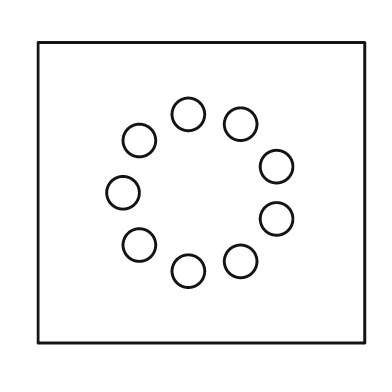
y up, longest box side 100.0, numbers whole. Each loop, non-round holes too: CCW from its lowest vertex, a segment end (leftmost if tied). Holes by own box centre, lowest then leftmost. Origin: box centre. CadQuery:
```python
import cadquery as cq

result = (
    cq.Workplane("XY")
    .moveTo(-50.0, -46.0)
    .lineTo(50.0, -46.0)
    .lineTo(50.0, 46.0)
    .lineTo(-50.0, 46.0)
    .close()
    .moveTo(-4.0, -24.0)
    .circle(5.0)
    .moveTo(12.0, -21.0)
    .circle(5.0)
    .moveTo(-19.0, -16.0)
    .circle(5.0)
    .moveTo(23.0, -8.0)
    .circle(5.0)
    .moveTo(-24.0, 0.0)
    .circle(5.0)
    .moveTo(23.0, 8.0)
    .circle(5.0)
    .moveTo(-19.0, 16.0)
    .circle(5.0)
    .moveTo(12.0, 21.0)
    .circle(5.0)
    .moveTo(-4.0, 24.0)
    .circle(5.0)
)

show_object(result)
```